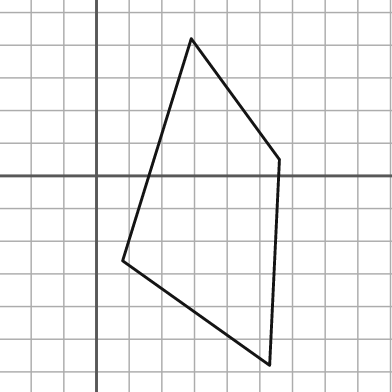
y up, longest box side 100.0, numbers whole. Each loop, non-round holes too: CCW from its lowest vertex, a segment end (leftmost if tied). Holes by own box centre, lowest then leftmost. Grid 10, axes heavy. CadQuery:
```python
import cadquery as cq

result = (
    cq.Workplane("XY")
    .moveTo(53.0, -58.0)
    .lineTo(56.0, 5.0)
    .lineTo(29.0, 42.0)
    .lineTo(8.0, -26.0)
    .close()
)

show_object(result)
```